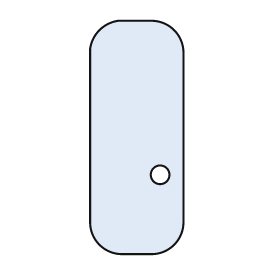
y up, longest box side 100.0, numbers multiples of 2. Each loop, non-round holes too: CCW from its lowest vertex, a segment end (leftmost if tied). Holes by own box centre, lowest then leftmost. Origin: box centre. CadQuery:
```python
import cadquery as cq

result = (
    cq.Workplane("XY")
    .moveTo(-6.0, -50.0)
    .lineTo(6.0, -50.0)
    .threePointArc((16.0, -46.0), (20.0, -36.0))
    .lineTo(20.0, 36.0)
    .threePointArc((16.0, 46.0), (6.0, 50.0))
    .lineTo(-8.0, 50.0)
    .threePointArc((-16.0, 46.0), (-20.0, 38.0))
    .lineTo(-20.0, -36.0)
    .threePointArc((-16.0, -46.0), (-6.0, -50.0))
    .close()
    .moveTo(10.0, -16.0)
    .circle(4.0)
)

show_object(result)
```